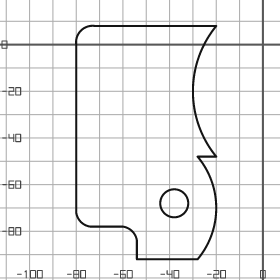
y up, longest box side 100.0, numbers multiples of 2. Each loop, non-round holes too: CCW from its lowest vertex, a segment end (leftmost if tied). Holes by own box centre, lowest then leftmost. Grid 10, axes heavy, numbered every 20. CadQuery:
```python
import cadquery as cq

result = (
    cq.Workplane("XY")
    .moveTo(-54.0, -92.0)
    .lineTo(-28.0, -92.0)
    .threePointArc((-20.0, -70.0), (-28.0, -48.0))
    .lineTo(-20.0, -48.0)
    .threePointArc((-30.0, -20.0), (-20.0, 8.0))
    .lineTo(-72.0, 8.0)
    .threePointArc((-78.0, 6.0), (-80.0, 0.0))
    .lineTo(-80.0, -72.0)
    .threePointArc((-78.0, -76.0), (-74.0, -78.0))
    .lineTo(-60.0, -78.0)
    .threePointArc((-56.0, -80.0), (-54.0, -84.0))
    .close()
    .moveTo(-38.0, -68.0)
    .circle(6.0)
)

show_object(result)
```